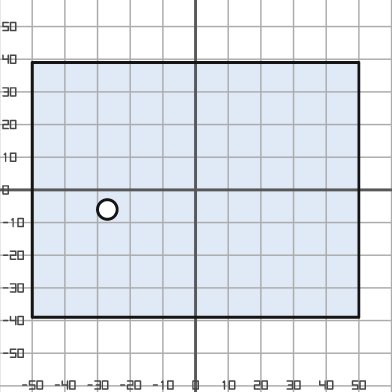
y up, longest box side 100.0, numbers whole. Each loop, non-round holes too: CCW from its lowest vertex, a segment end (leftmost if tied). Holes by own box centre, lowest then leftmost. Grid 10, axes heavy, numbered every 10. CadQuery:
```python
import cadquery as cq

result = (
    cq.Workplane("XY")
    .moveTo(-50.0, -39.0)
    .lineTo(50.0, -39.0)
    .lineTo(50.0, 39.0)
    .lineTo(-50.0, 39.0)
    .close()
    .moveTo(-27.0, -6.0)
    .circle(3.0)
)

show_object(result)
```